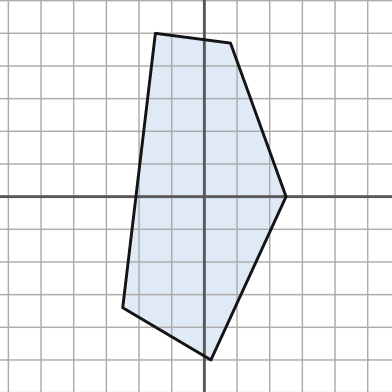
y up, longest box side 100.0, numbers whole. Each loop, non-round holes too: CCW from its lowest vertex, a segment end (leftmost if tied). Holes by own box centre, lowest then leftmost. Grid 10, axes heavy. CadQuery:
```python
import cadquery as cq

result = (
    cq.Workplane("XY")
    .moveTo(2.0, -50.0)
    .lineTo(25.0, 0.0)
    .lineTo(8.0, 47.0)
    .lineTo(-15.0, 50.0)
    .lineTo(-25.0, -34.0)
    .close()
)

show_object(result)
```